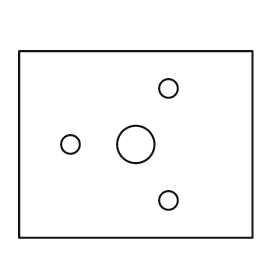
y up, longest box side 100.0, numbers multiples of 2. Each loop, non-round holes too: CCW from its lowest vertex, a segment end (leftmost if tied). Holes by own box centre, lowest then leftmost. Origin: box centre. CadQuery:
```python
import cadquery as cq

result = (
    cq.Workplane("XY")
    .moveTo(-50.0, -40.0)
    .lineTo(50.0, -40.0)
    .lineTo(50.0, 40.0)
    .lineTo(-50.0, 40.0)
    .close()
    .moveTo(14.0, -24.0)
    .circle(4.0)
    .moveTo(-28.0, 0.0)
    .circle(4.0)
    .moveTo(0.0, 0.0)
    .circle(8.0)
    .moveTo(14.0, 24.0)
    .circle(4.0)
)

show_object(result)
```